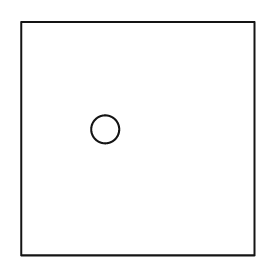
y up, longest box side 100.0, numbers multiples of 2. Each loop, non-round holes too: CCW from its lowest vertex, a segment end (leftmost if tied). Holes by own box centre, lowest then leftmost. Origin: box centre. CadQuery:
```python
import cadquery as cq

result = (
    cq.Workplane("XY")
    .moveTo(-50.0, -50.0)
    .lineTo(50.0, -50.0)
    .lineTo(50.0, 50.0)
    .lineTo(-50.0, 50.0)
    .close()
    .moveTo(-14.0, 4.0)
    .circle(6.0)
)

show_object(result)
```